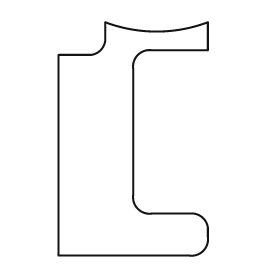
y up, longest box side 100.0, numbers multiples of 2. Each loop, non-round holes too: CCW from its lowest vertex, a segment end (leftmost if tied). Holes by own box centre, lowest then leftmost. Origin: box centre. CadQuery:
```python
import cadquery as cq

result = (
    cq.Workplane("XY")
    .moveTo(-32.0, -50.0)
    .lineTo(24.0, -50.0)
    .threePointArc((30.0, -48.0), (32.0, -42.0))
    .lineTo(32.0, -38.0)
    .threePointArc((30.0, -34.0), (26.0, -32.0))
    .lineTo(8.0, -32.0)
    .threePointArc((2.0, -30.0), (0.0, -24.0))
    .lineTo(0.0, 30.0)
    .threePointArc((2.0, 36.0), (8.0, 38.0))
    .lineTo(32.0, 38.0)
    .lineTo(32.0, 50.0)
    .threePointArc((10.0, 46.0), (-12.0, 50.0))
    .lineTo(-12.0, 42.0)
    .threePointArc((-14.0, 38.0), (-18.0, 36.0))
    .lineTo(-32.0, 36.0)
    .close()
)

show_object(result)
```